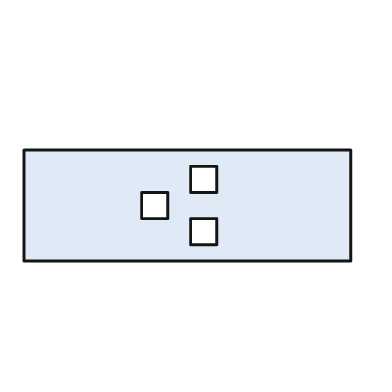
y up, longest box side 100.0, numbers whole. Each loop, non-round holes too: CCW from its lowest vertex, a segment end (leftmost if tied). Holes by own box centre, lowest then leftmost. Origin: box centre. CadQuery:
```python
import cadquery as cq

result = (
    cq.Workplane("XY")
    .moveTo(-50.0, -17.0)
    .lineTo(50.0, -17.0)
    .lineTo(50.0, 17.0)
    .lineTo(-50.0, 17.0)
    .close()
    .moveTo(1.0, -12.0)
    .lineTo(9.0, -12.0)
    .lineTo(9.0, -4.0)
    .lineTo(1.0, -4.0)
    .close()
    .moveTo(-14.0, -4.0)
    .lineTo(-6.0, -4.0)
    .lineTo(-6.0, 4.0)
    .lineTo(-14.0, 4.0)
    .close()
    .moveTo(1.0, 4.0)
    .lineTo(9.0, 4.0)
    .lineTo(9.0, 12.0)
    .lineTo(1.0, 12.0)
    .close()
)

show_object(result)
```